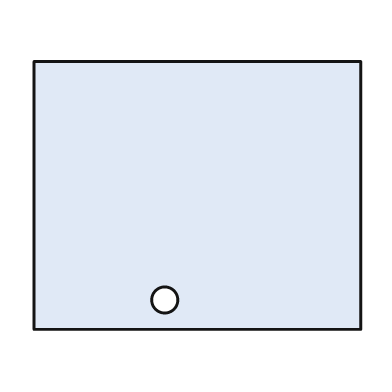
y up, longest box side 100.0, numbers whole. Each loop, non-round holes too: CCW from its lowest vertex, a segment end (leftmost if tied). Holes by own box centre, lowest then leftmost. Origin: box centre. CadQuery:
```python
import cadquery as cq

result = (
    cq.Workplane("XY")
    .moveTo(-50.0, -41.0)
    .lineTo(50.0, -41.0)
    .lineTo(50.0, 41.0)
    .lineTo(-50.0, 41.0)
    .close()
    .moveTo(-10.0, -32.0)
    .circle(4.0)
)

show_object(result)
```